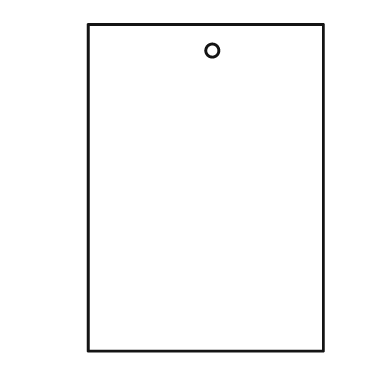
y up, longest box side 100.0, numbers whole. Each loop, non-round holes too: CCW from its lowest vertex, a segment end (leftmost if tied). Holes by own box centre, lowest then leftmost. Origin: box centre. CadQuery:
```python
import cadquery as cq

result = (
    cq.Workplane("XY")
    .moveTo(-36.0, -50.0)
    .lineTo(36.0, -50.0)
    .lineTo(36.0, 50.0)
    .lineTo(-36.0, 50.0)
    .close()
    .moveTo(2.0, 42.0)
    .circle(2.0)
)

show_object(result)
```